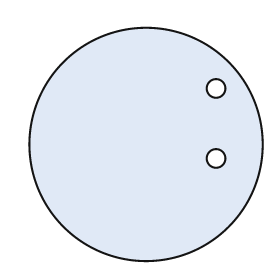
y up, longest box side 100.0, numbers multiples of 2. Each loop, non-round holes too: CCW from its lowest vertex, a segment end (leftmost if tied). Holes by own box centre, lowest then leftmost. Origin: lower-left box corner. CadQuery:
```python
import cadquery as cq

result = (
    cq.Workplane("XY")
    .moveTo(50.0, 50.0)
    .circle(50.0)
    .moveTo(80.0, 44.0)
    .circle(4.0)
    .moveTo(80.0, 74.0)
    .circle(4.0)
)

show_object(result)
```